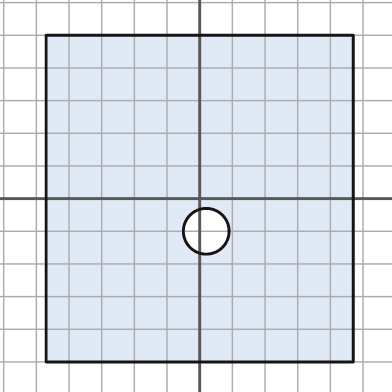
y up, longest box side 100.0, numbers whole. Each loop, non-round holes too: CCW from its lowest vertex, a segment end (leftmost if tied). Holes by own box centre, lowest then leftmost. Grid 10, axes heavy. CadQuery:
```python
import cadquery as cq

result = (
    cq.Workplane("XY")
    .moveTo(-47.0, -50.0)
    .lineTo(47.0, -50.0)
    .lineTo(47.0, 50.0)
    .lineTo(-47.0, 50.0)
    .close()
    .moveTo(2.0, -10.0)
    .circle(7.0)
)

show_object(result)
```